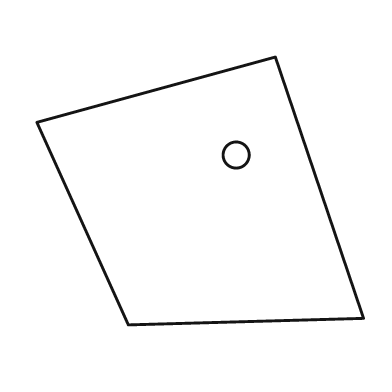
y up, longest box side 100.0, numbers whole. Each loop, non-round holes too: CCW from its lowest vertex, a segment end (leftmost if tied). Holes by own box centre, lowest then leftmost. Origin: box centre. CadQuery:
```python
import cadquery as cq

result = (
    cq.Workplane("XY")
    .moveTo(-22.0, -41.0)
    .lineTo(50.0, -39.0)
    .lineTo(23.0, 41.0)
    .lineTo(-50.0, 21.0)
    .close()
    .moveTo(11.0, 11.0)
    .circle(4.0)
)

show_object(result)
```